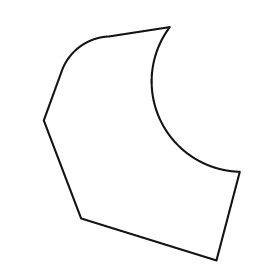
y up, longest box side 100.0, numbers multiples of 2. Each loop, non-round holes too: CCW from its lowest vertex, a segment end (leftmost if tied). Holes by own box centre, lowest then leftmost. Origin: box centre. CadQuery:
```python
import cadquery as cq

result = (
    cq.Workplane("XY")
    .moveTo(32.0, -50.0)
    .lineTo(42.0, -12.0)
    .threePointArc((8.0, 10.0), (12.0, 50.0))
    .lineTo(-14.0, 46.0)
    .threePointArc((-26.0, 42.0), (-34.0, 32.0))
    .lineTo(-42.0, 10.0)
    .lineTo(-26.0, -32.0)
    .close()
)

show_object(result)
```